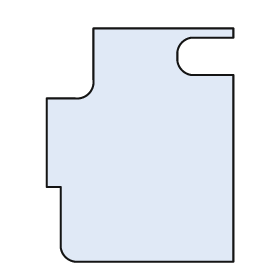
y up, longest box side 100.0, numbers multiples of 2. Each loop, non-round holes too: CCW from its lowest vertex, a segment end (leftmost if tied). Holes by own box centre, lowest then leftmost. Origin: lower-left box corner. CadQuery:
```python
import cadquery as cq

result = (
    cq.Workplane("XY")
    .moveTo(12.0, 0.0)
    .lineTo(80.0, 0.0)
    .lineTo(80.0, 80.0)
    .lineTo(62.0, 80.0)
    .threePointArc((58.0, 82.0), (56.0, 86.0))
    .lineTo(56.0, 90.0)
    .threePointArc((58.0, 94.0), (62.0, 96.0))
    .lineTo(80.0, 96.0)
    .lineTo(80.0, 100.0)
    .lineTo(20.0, 100.0)
    .lineTo(20.0, 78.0)
    .threePointArc((18.0, 72.0), (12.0, 70.0))
    .lineTo(0.0, 70.0)
    .lineTo(0.0, 32.0)
    .lineTo(6.0, 32.0)
    .lineTo(6.0, 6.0)
    .threePointArc((8.0, 2.0), (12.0, 0.0))
    .close()
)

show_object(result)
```